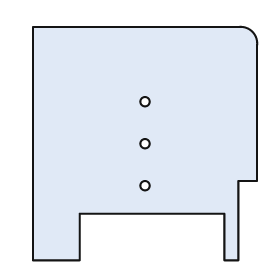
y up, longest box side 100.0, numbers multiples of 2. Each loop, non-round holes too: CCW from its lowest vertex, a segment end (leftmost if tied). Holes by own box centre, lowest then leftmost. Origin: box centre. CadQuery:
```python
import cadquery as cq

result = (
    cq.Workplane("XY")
    .moveTo(-48.0, -50.0)
    .lineTo(-28.0, -50.0)
    .lineTo(-28.0, -30.0)
    .lineTo(34.0, -30.0)
    .lineTo(34.0, -50.0)
    .lineTo(40.0, -50.0)
    .lineTo(40.0, -16.0)
    .lineTo(48.0, -16.0)
    .lineTo(48.0, 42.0)
    .threePointArc((46.0, 48.0), (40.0, 50.0))
    .lineTo(-48.0, 50.0)
    .close()
    .moveTo(0.0, -18.0)
    .circle(2.0)
    .moveTo(0.0, 0.0)
    .circle(2.0)
    .moveTo(0.0, 18.0)
    .circle(2.0)
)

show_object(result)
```